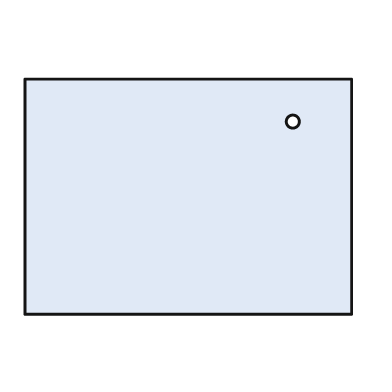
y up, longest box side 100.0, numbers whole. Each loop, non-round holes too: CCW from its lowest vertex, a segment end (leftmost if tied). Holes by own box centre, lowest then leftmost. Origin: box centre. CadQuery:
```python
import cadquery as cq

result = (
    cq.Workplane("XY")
    .moveTo(-50.0, -36.0)
    .lineTo(50.0, -36.0)
    .lineTo(50.0, 36.0)
    .lineTo(-50.0, 36.0)
    .close()
    .moveTo(32.0, 23.0)
    .circle(2.0)
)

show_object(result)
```